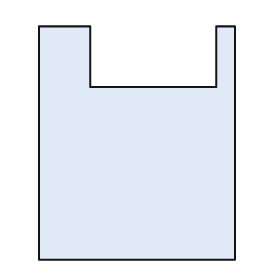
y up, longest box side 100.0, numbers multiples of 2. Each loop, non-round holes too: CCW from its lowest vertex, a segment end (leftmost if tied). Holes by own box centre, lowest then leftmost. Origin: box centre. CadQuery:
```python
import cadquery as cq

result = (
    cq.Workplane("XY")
    .moveTo(-42.0, -50.0)
    .lineTo(42.0, -50.0)
    .lineTo(42.0, 50.0)
    .lineTo(34.0, 50.0)
    .lineTo(34.0, 24.0)
    .lineTo(-20.0, 24.0)
    .lineTo(-20.0, 50.0)
    .lineTo(-42.0, 50.0)
    .close()
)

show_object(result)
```